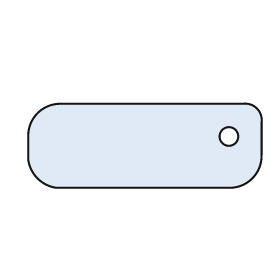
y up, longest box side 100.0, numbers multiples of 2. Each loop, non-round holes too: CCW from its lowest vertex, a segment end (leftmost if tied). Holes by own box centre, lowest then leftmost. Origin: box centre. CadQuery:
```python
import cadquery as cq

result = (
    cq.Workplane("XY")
    .moveTo(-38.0, -18.0)
    .lineTo(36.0, -18.0)
    .threePointArc((46.0, -14.0), (50.0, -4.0))
    .lineTo(50.0, 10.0)
    .threePointArc((48.0, 16.0), (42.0, 18.0))
    .lineTo(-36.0, 18.0)
    .threePointArc((-46.0, 14.0), (-50.0, 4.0))
    .lineTo(-50.0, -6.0)
    .threePointArc((-46.0, -14.0), (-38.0, -18.0))
    .close()
    .moveTo(36.0, 4.0)
    .circle(4.0)
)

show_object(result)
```